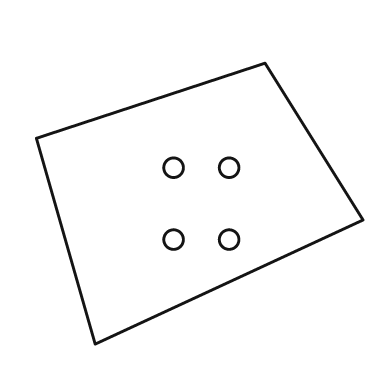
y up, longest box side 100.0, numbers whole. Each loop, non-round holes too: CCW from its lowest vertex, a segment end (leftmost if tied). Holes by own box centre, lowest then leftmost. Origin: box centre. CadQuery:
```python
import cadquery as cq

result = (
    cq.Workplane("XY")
    .moveTo(-32.0, -43.0)
    .lineTo(50.0, -5.0)
    .lineTo(20.0, 43.0)
    .lineTo(-50.0, 20.0)
    .close()
    .moveTo(-8.0, -11.0)
    .circle(3.0)
    .moveTo(9.0, -11.0)
    .circle(3.0)
    .moveTo(-8.0, 11.0)
    .circle(3.0)
    .moveTo(9.0, 11.0)
    .circle(3.0)
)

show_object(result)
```